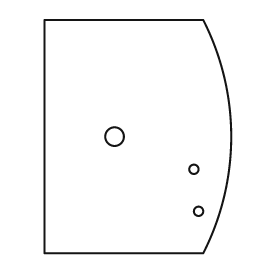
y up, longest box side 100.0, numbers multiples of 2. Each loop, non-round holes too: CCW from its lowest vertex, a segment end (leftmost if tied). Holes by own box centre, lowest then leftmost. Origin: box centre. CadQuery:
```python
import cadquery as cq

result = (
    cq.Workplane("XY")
    .moveTo(-40.0, -50.0)
    .lineTo(28.0, -50.0)
    .threePointArc((40.0, 0.0), (28.0, 50.0))
    .lineTo(-40.0, 50.0)
    .close()
    .moveTo(26.0, -32.0)
    .circle(2.0)
    .moveTo(24.0, -14.0)
    .circle(2.0)
    .moveTo(-10.0, 0.0)
    .circle(4.0)
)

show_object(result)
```